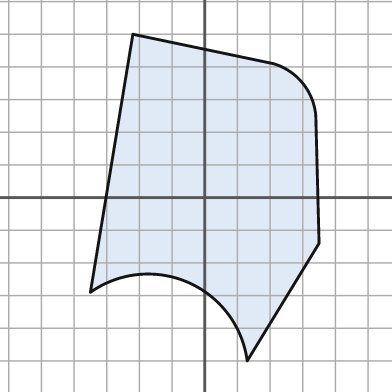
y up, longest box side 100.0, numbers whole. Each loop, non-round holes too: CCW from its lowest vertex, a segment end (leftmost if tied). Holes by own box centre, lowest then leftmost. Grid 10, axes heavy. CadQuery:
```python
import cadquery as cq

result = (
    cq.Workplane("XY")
    .moveTo(13.0, -50.0)
    .lineTo(35.0, -14.0)
    .lineTo(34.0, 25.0)
    .threePointArc((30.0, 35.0), (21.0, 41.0))
    .lineTo(-22.0, 50.0)
    .lineTo(-35.0, -29.0)
    .threePointArc((-5.0, -26.0), (13.0, -50.0))
    .close()
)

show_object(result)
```